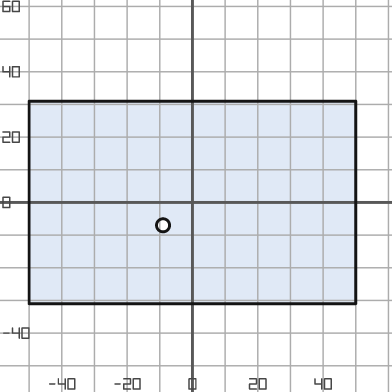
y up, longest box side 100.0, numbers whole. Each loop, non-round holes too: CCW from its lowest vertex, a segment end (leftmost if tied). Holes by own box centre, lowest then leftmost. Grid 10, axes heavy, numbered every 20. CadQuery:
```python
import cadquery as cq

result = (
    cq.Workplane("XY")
    .moveTo(-50.0, -31.0)
    .lineTo(50.0, -31.0)
    .lineTo(50.0, 31.0)
    .lineTo(-50.0, 31.0)
    .close()
    .moveTo(-9.0, -7.0)
    .circle(2.0)
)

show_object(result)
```